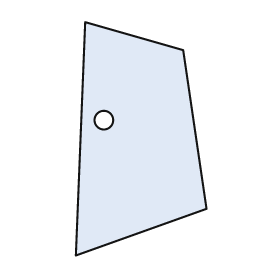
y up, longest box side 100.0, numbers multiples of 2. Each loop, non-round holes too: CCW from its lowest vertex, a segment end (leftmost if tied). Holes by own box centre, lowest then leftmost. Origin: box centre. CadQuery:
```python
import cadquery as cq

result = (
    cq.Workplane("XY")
    .moveTo(-28.0, -50.0)
    .lineTo(28.0, -30.0)
    .lineTo(18.0, 38.0)
    .lineTo(-24.0, 50.0)
    .close()
    .moveTo(-16.0, 8.0)
    .circle(4.0)
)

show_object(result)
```